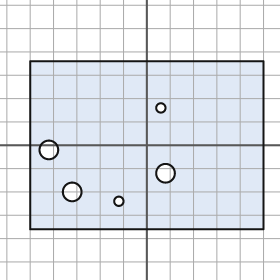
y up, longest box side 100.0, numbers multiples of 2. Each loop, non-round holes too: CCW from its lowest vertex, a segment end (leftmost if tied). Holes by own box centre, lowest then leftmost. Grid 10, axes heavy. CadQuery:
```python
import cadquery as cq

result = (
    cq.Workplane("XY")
    .moveTo(-50.0, -36.0)
    .lineTo(50.0, -36.0)
    .lineTo(50.0, 36.0)
    .lineTo(-50.0, 36.0)
    .close()
    .moveTo(-12.0, -24.0)
    .circle(2.0)
    .moveTo(-32.0, -20.0)
    .circle(4.0)
    .moveTo(8.0, -12.0)
    .circle(4.0)
    .moveTo(-42.0, -2.0)
    .circle(4.0)
    .moveTo(6.0, 16.0)
    .circle(2.0)
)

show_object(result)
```